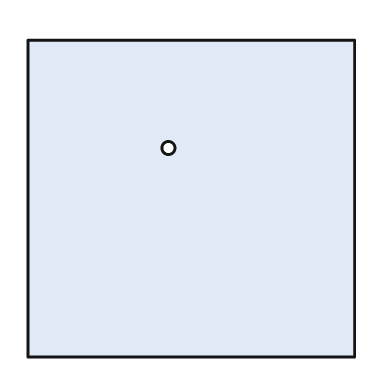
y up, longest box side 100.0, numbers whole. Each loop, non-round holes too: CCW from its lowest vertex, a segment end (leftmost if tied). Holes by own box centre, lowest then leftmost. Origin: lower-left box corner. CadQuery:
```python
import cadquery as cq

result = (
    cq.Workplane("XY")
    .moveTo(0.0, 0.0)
    .lineTo(100.0, 0.0)
    .lineTo(100.0, 97.0)
    .lineTo(0.0, 97.0)
    .close()
    .moveTo(43.0, 64.0)
    .circle(2.0)
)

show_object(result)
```